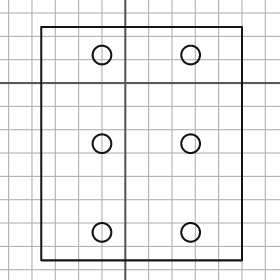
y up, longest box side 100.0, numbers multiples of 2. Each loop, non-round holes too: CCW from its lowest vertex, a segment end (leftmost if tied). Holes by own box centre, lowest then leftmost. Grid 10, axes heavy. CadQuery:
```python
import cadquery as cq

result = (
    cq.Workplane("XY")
    .moveTo(-36.0, -76.0)
    .lineTo(50.0, -76.0)
    .lineTo(50.0, 24.0)
    .lineTo(-36.0, 24.0)
    .close()
    .moveTo(-10.0, -64.0)
    .circle(4.0)
    .moveTo(28.0, -64.0)
    .circle(4.0)
    .moveTo(-10.0, -26.0)
    .circle(4.0)
    .moveTo(28.0, -26.0)
    .circle(4.0)
    .moveTo(-10.0, 12.0)
    .circle(4.0)
    .moveTo(28.0, 12.0)
    .circle(4.0)
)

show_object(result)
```